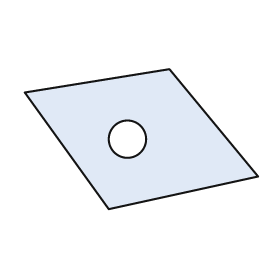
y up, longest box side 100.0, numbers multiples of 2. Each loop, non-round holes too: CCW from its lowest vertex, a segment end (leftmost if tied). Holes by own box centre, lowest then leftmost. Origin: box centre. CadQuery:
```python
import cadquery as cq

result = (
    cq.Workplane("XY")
    .moveTo(-14.0, -30.0)
    .lineTo(50.0, -16.0)
    .lineTo(12.0, 30.0)
    .lineTo(-50.0, 20.0)
    .close()
    .moveTo(-6.0, 0.0)
    .circle(8.0)
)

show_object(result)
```